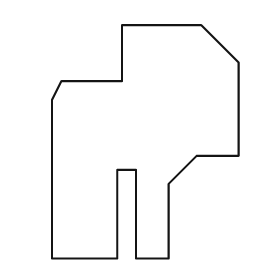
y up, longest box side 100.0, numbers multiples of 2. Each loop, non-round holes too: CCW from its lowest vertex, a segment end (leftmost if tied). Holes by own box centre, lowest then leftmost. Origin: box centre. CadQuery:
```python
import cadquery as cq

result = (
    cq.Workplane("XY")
    .moveTo(-40.0, -50.0)
    .lineTo(-12.0, -50.0)
    .lineTo(-12.0, -12.0)
    .lineTo(-4.0, -12.0)
    .lineTo(-4.0, -50.0)
    .lineTo(10.0, -50.0)
    .lineTo(10.0, -18.0)
    .lineTo(22.0, -6.0)
    .lineTo(40.0, -6.0)
    .lineTo(40.0, 34.0)
    .lineTo(24.0, 50.0)
    .lineTo(-10.0, 50.0)
    .lineTo(-10.0, 26.0)
    .lineTo(-36.0, 26.0)
    .lineTo(-40.0, 18.0)
    .close()
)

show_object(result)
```